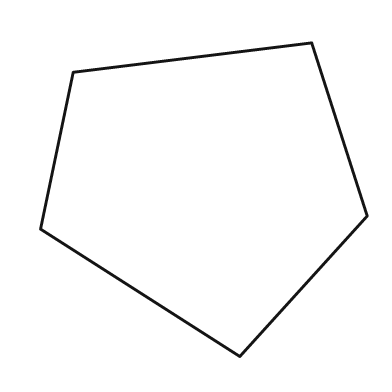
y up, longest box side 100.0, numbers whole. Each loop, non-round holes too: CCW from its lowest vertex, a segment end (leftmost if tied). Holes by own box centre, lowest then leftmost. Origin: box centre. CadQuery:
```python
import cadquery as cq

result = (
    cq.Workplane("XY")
    .moveTo(11.0, -48.0)
    .lineTo(50.0, -5.0)
    .lineTo(33.0, 48.0)
    .lineTo(-40.0, 39.0)
    .lineTo(-50.0, -9.0)
    .close()
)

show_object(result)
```